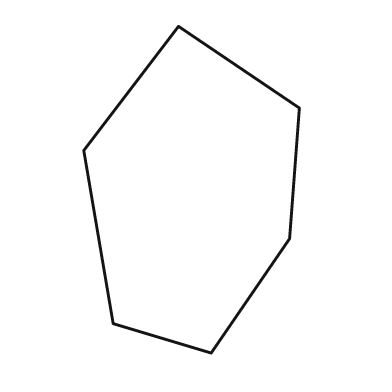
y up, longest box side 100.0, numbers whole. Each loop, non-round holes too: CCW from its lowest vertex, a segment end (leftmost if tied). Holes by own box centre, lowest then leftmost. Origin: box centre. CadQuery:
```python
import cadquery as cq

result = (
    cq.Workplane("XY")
    .moveTo(6.0, -50.0)
    .lineTo(30.0, -15.0)
    .lineTo(33.0, 25.0)
    .lineTo(-4.0, 50.0)
    .lineTo(-33.0, 12.0)
    .lineTo(-24.0, -41.0)
    .close()
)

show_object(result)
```